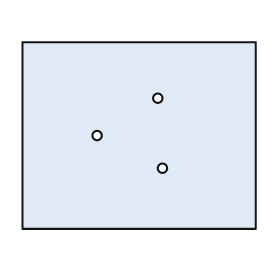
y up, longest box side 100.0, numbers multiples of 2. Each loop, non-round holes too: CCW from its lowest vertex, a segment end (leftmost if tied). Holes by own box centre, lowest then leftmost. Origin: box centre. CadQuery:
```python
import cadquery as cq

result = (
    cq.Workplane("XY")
    .moveTo(-50.0, -40.0)
    .lineTo(50.0, -40.0)
    .lineTo(50.0, 40.0)
    .lineTo(-50.0, 40.0)
    .close()
    .moveTo(10.0, -14.0)
    .circle(2.0)
    .moveTo(-18.0, 0.0)
    .circle(2.0)
    .moveTo(8.0, 16.0)
    .circle(2.0)
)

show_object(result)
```